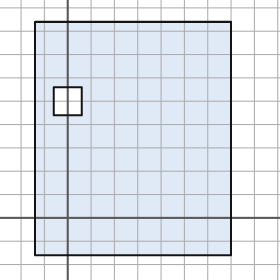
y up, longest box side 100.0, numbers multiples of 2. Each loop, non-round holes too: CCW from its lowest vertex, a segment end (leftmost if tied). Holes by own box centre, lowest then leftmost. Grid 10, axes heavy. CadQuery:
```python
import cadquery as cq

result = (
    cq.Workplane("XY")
    .moveTo(-14.0, -16.0)
    .lineTo(70.0, -16.0)
    .lineTo(70.0, 84.0)
    .lineTo(-14.0, 84.0)
    .close()
    .moveTo(-6.0, 44.0)
    .lineTo(6.0, 44.0)
    .lineTo(6.0, 56.0)
    .lineTo(-6.0, 56.0)
    .close()
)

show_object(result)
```